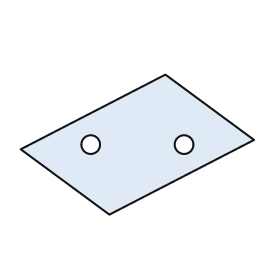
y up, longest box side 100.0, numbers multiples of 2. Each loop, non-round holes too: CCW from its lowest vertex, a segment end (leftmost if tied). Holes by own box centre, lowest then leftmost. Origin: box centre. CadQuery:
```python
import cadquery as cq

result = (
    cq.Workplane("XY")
    .moveTo(-12.0, -30.0)
    .lineTo(50.0, 2.0)
    .lineTo(12.0, 30.0)
    .lineTo(-50.0, -2.0)
    .close()
    .moveTo(-20.0, 0.0)
    .circle(4.0)
    .moveTo(20.0, 0.0)
    .circle(4.0)
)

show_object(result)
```